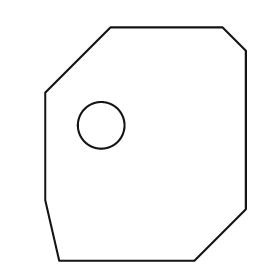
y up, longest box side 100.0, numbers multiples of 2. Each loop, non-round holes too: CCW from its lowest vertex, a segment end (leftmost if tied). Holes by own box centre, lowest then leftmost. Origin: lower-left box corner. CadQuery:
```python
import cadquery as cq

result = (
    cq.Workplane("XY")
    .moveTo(6.0, 0.0)
    .lineTo(64.0, 0.0)
    .lineTo(86.0, 22.0)
    .lineTo(86.0, 90.0)
    .lineTo(76.0, 100.0)
    .lineTo(28.0, 100.0)
    .lineTo(0.0, 72.0)
    .lineTo(0.0, 26.0)
    .close()
    .moveTo(24.0, 58.0)
    .circle(10.0)
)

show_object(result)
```